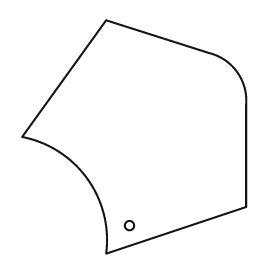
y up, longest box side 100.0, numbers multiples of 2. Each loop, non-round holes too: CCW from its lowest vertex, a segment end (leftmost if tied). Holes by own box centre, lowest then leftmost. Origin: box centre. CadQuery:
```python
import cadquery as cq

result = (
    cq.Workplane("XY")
    .moveTo(-12.0, -50.0)
    .lineTo(48.0, -30.0)
    .lineTo(48.0, 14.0)
    .threePointArc((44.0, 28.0), (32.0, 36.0))
    .lineTo(-12.0, 50.0)
    .lineTo(-48.0, 0.0)
    .threePointArc((-20.0, -18.0), (-12.0, -50.0))
    .close()
    .moveTo(-2.0, -38.0)
    .circle(2.0)
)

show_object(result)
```